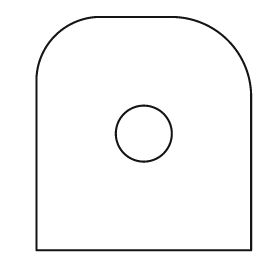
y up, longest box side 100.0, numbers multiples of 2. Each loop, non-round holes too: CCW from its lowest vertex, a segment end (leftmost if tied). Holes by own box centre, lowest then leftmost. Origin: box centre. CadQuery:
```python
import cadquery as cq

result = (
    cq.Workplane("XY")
    .moveTo(-46.0, -50.0)
    .lineTo(46.0, -50.0)
    .lineTo(46.0, 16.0)
    .threePointArc((36.0, 40.0), (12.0, 50.0))
    .lineTo(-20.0, 50.0)
    .threePointArc((-38.0, 42.0), (-46.0, 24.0))
    .close()
    .moveTo(0.0, 0.0)
    .circle(12.0)
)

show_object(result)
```